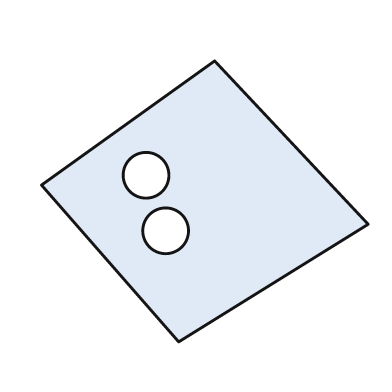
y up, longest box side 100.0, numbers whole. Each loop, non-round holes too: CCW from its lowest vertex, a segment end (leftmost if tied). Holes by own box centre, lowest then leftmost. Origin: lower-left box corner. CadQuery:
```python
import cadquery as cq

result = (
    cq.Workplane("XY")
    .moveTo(42.0, 0.0)
    .lineTo(100.0, 36.0)
    .lineTo(53.0, 86.0)
    .lineTo(0.0, 48.0)
    .close()
    .moveTo(38.0, 34.0)
    .circle(7.0)
    .moveTo(32.0, 51.0)
    .circle(7.0)
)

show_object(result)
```